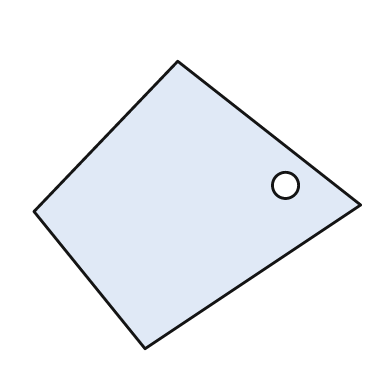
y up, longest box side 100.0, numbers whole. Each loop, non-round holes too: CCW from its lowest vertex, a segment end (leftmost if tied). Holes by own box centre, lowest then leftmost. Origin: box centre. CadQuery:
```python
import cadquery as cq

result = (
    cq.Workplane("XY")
    .moveTo(-16.0, -44.0)
    .lineTo(50.0, 0.0)
    .lineTo(-6.0, 44.0)
    .lineTo(-50.0, -2.0)
    .close()
    .moveTo(27.0, 6.0)
    .circle(4.0)
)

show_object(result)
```